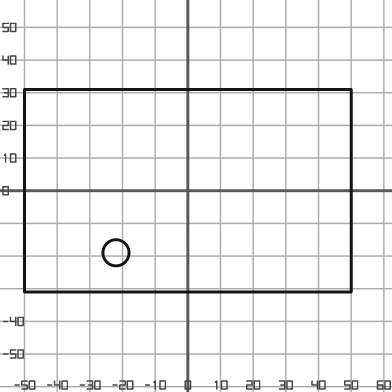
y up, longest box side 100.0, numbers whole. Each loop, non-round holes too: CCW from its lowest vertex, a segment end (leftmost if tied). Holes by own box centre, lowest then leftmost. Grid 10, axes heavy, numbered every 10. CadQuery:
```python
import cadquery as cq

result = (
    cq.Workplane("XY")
    .moveTo(-50.0, -31.0)
    .lineTo(50.0, -31.0)
    .lineTo(50.0, 31.0)
    .lineTo(-50.0, 31.0)
    .close()
    .moveTo(-22.0, -19.0)
    .circle(4.0)
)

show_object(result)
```